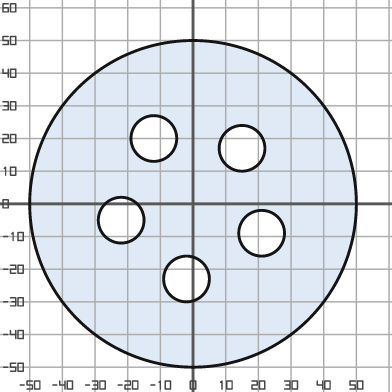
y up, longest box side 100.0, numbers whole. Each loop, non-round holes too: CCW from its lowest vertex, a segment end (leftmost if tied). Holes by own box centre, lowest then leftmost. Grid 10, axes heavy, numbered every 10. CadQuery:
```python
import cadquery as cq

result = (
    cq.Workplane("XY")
    .moveTo(0.0, 0.0)
    .circle(50.0)
    .moveTo(-2.0, -23.0)
    .circle(7.0)
    .moveTo(21.0, -9.0)
    .circle(7.0)
    .moveTo(-22.0, -5.0)
    .circle(7.0)
    .moveTo(15.0, 17.0)
    .circle(7.0)
    .moveTo(-12.0, 20.0)
    .circle(7.0)
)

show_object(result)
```